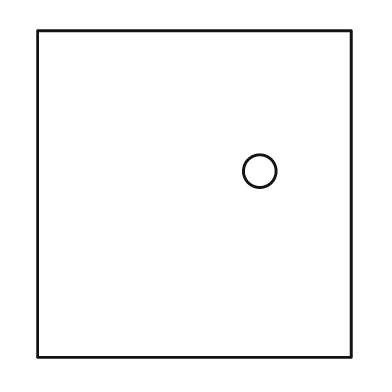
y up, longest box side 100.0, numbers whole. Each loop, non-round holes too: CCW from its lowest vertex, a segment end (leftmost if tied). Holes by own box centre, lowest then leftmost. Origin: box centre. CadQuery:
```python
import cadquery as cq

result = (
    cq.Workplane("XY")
    .moveTo(-48.0, -50.0)
    .lineTo(48.0, -50.0)
    .lineTo(48.0, 50.0)
    .lineTo(-48.0, 50.0)
    .close()
    .moveTo(20.0, 7.0)
    .circle(5.0)
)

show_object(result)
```